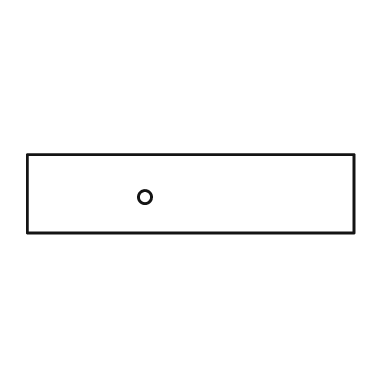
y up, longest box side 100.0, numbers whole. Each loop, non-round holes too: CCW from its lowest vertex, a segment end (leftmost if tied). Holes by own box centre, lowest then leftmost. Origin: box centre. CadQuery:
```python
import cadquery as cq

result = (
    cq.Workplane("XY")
    .moveTo(-50.0, -12.0)
    .lineTo(50.0, -12.0)
    .lineTo(50.0, 12.0)
    .lineTo(-50.0, 12.0)
    .close()
    .moveTo(-14.0, -1.0)
    .circle(2.0)
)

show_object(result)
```